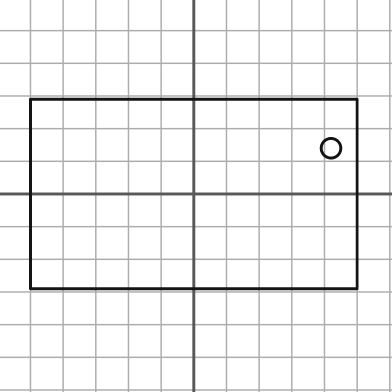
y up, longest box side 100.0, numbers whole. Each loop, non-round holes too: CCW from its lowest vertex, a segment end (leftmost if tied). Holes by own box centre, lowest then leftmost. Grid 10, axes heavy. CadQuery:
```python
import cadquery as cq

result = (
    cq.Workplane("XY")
    .moveTo(-50.0, -29.0)
    .lineTo(50.0, -29.0)
    .lineTo(50.0, 29.0)
    .lineTo(-50.0, 29.0)
    .close()
    .moveTo(42.0, 14.0)
    .circle(3.0)
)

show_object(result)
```